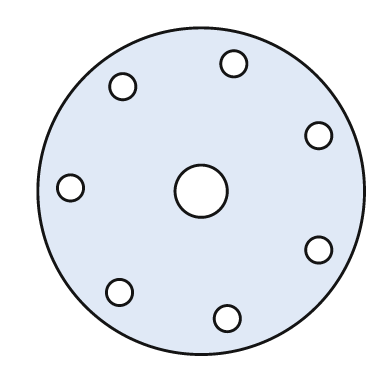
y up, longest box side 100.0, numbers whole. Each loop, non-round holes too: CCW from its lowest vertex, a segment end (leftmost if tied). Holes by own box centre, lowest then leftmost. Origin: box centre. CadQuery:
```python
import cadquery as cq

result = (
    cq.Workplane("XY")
    .moveTo(0.0, 0.0)
    .circle(50.0)
    .moveTo(8.0, -39.0)
    .circle(4.0)
    .moveTo(-25.0, -31.0)
    .circle(4.0)
    .moveTo(36.0, -18.0)
    .circle(4.0)
    .moveTo(0.0, 0.0)
    .circle(8.0)
    .moveTo(-40.0, 1.0)
    .circle(4.0)
    .moveTo(36.0, 17.0)
    .circle(4.0)
    .moveTo(-24.0, 32.0)
    .circle(4.0)
    .moveTo(10.0, 39.0)
    .circle(4.0)
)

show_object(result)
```